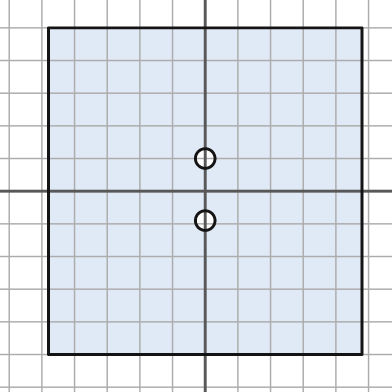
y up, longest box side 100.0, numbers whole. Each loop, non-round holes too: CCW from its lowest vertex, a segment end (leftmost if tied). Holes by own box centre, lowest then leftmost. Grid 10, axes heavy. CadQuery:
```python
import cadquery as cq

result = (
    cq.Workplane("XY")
    .moveTo(-48.0, -50.0)
    .lineTo(48.0, -50.0)
    .lineTo(48.0, 50.0)
    .lineTo(-48.0, 50.0)
    .close()
    .moveTo(0.0, -9.0)
    .circle(3.0)
    .moveTo(0.0, 10.0)
    .circle(3.0)
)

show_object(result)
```